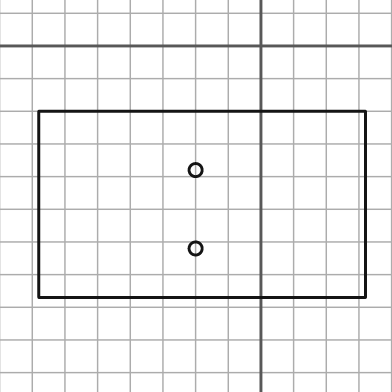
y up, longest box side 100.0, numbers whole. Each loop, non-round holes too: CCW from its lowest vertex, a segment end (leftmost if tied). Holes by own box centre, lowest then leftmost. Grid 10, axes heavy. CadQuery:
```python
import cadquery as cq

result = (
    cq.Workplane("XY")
    .moveTo(-68.0, -77.0)
    .lineTo(32.0, -77.0)
    .lineTo(32.0, -20.0)
    .lineTo(-68.0, -20.0)
    .close()
    .moveTo(-20.0, -62.0)
    .circle(2.0)
    .moveTo(-20.0, -38.0)
    .circle(2.0)
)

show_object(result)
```